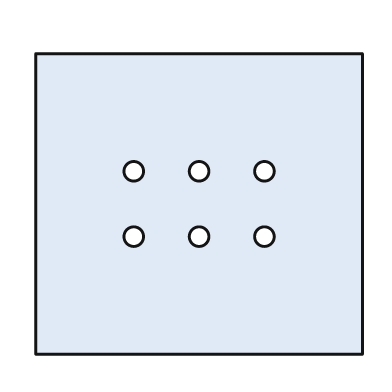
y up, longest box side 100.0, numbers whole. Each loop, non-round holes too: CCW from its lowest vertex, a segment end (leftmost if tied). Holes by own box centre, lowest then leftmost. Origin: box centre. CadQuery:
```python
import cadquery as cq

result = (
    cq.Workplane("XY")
    .moveTo(-50.0, -46.0)
    .lineTo(50.0, -46.0)
    .lineTo(50.0, 46.0)
    .lineTo(-50.0, 46.0)
    .close()
    .moveTo(-20.0, -10.0)
    .circle(3.0)
    .moveTo(0.0, -10.0)
    .circle(3.0)
    .moveTo(20.0, -10.0)
    .circle(3.0)
    .moveTo(-20.0, 10.0)
    .circle(3.0)
    .moveTo(0.0, 10.0)
    .circle(3.0)
    .moveTo(20.0, 10.0)
    .circle(3.0)
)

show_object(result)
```